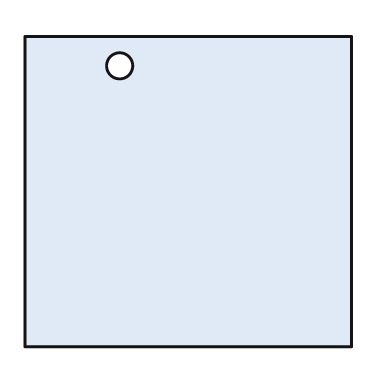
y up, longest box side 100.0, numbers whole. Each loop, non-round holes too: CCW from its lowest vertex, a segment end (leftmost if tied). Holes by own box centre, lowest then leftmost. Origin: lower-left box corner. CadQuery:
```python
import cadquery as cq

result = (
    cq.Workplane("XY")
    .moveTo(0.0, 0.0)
    .lineTo(100.0, 0.0)
    .lineTo(100.0, 95.0)
    .lineTo(0.0, 95.0)
    .close()
    .moveTo(29.0, 86.0)
    .circle(4.0)
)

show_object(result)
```